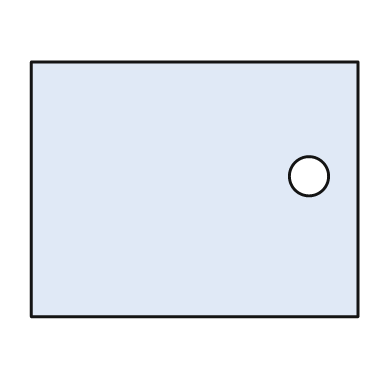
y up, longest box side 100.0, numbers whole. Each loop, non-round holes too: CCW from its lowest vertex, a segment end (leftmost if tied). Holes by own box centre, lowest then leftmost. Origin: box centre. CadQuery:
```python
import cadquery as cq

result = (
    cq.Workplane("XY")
    .moveTo(-50.0, -39.0)
    .lineTo(50.0, -39.0)
    .lineTo(50.0, 39.0)
    .lineTo(-50.0, 39.0)
    .close()
    .moveTo(35.0, 4.0)
    .circle(6.0)
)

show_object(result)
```